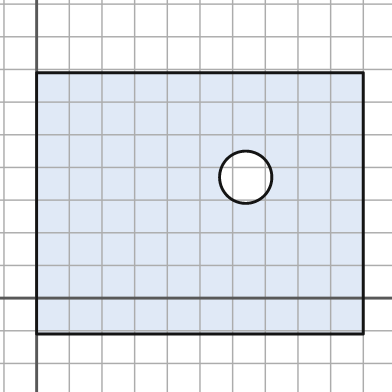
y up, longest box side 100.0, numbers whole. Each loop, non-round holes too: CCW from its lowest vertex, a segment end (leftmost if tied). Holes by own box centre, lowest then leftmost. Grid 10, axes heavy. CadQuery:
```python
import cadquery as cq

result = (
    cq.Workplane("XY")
    .moveTo(0.0, -11.0)
    .lineTo(100.0, -11.0)
    .lineTo(100.0, 69.0)
    .lineTo(0.0, 69.0)
    .close()
    .moveTo(64.0, 37.0)
    .circle(8.0)
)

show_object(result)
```